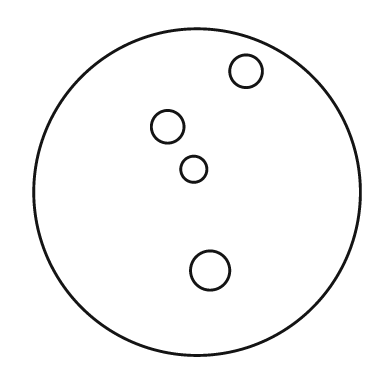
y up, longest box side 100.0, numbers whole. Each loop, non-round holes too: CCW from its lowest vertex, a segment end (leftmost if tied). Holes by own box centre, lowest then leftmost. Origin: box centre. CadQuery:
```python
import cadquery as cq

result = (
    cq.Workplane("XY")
    .moveTo(0.0, 0.0)
    .circle(50.0)
    .moveTo(4.0, -24.0)
    .circle(6.0)
    .moveTo(-1.0, 7.0)
    .circle(4.0)
    .moveTo(-9.0, 20.0)
    .circle(5.0)
    .moveTo(15.0, 37.0)
    .circle(5.0)
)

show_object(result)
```